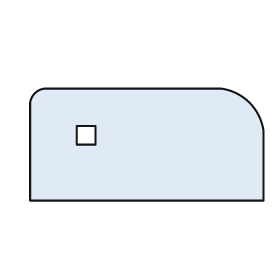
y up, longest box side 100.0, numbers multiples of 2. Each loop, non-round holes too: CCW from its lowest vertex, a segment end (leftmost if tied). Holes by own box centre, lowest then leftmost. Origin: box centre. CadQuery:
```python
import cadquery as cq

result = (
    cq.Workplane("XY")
    .moveTo(-50.0, -24.0)
    .lineTo(50.0, -24.0)
    .lineTo(50.0, 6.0)
    .threePointArc((44.0, 18.0), (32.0, 24.0))
    .lineTo(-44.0, 24.0)
    .threePointArc((-48.0, 22.0), (-50.0, 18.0))
    .close()
    .moveTo(-30.0, 0.0)
    .lineTo(-22.0, 0.0)
    .lineTo(-22.0, 8.0)
    .lineTo(-30.0, 8.0)
    .close()
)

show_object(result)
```